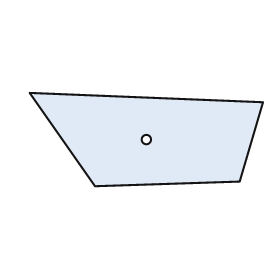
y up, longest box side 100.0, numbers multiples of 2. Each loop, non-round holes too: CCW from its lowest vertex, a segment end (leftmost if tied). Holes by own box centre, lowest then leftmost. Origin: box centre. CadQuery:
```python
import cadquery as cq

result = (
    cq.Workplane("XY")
    .moveTo(-22.0, -20.0)
    .lineTo(40.0, -18.0)
    .lineTo(50.0, 16.0)
    .lineTo(-50.0, 20.0)
    .close()
    .moveTo(0.0, 0.0)
    .circle(2.0)
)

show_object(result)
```